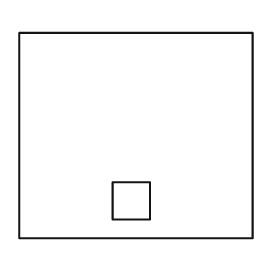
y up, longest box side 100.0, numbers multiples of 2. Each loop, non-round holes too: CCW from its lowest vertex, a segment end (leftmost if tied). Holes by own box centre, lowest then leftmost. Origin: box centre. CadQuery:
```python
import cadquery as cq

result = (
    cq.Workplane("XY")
    .moveTo(-50.0, -44.0)
    .lineTo(50.0, -44.0)
    .lineTo(50.0, 44.0)
    .lineTo(-50.0, 44.0)
    .close()
    .moveTo(-10.0, -36.0)
    .lineTo(6.0, -36.0)
    .lineTo(6.0, -20.0)
    .lineTo(-10.0, -20.0)
    .close()
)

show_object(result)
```